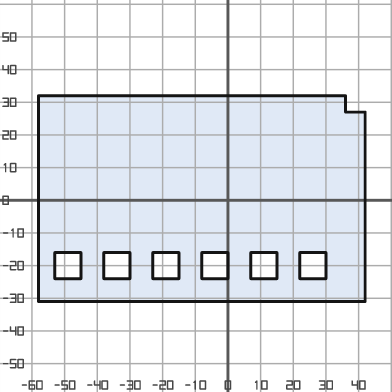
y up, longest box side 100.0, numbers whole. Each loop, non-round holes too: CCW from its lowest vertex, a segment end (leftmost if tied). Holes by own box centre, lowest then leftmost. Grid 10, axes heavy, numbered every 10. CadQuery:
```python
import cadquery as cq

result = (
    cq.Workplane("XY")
    .moveTo(-58.0, -31.0)
    .lineTo(42.0, -31.0)
    .lineTo(42.0, 27.0)
    .lineTo(36.0, 27.0)
    .lineTo(36.0, 32.0)
    .lineTo(-58.0, 32.0)
    .close()
    .moveTo(-53.0, -24.0)
    .lineTo(-45.0, -24.0)
    .lineTo(-45.0, -16.0)
    .lineTo(-53.0, -16.0)
    .close()
    .moveTo(-38.0, -24.0)
    .lineTo(-30.0, -24.0)
    .lineTo(-30.0, -16.0)
    .lineTo(-38.0, -16.0)
    .close()
    .moveTo(-23.0, -24.0)
    .lineTo(-15.0, -24.0)
    .lineTo(-15.0, -16.0)
    .lineTo(-23.0, -16.0)
    .close()
    .moveTo(-8.0, -24.0)
    .lineTo(0.0, -24.0)
    .lineTo(0.0, -16.0)
    .lineTo(-8.0, -16.0)
    .close()
    .moveTo(7.0, -24.0)
    .lineTo(15.0, -24.0)
    .lineTo(15.0, -16.0)
    .lineTo(7.0, -16.0)
    .close()
    .moveTo(22.0, -24.0)
    .lineTo(30.0, -24.0)
    .lineTo(30.0, -16.0)
    .lineTo(22.0, -16.0)
    .close()
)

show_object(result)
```